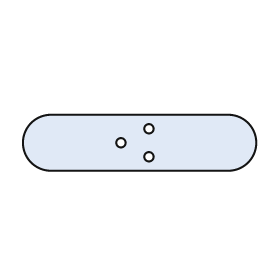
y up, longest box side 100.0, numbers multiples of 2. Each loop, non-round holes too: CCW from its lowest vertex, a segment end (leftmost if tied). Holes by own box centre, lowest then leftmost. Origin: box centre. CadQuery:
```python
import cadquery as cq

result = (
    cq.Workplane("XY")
    .moveTo(-38.0, -12.0)
    .lineTo(38.0, -12.0)
    .threePointArc((50.0, 0.0), (38.0, 12.0))
    .lineTo(-38.0, 12.0)
    .threePointArc((-50.0, 0.0), (-38.0, -12.0))
    .close()
    .moveTo(4.0, -6.0)
    .circle(2.0)
    .moveTo(-8.0, 0.0)
    .circle(2.0)
    .moveTo(4.0, 6.0)
    .circle(2.0)
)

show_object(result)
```